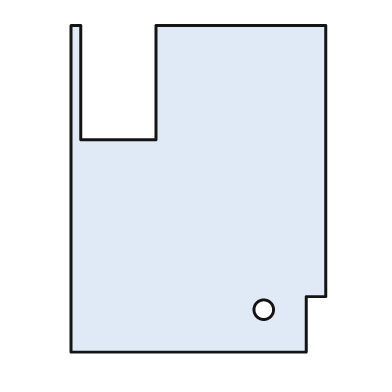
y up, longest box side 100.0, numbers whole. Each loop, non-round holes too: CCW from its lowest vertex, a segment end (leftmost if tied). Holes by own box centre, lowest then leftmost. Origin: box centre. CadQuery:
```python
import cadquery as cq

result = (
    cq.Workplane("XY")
    .moveTo(-39.0, -50.0)
    .lineTo(33.0, -50.0)
    .lineTo(33.0, -33.0)
    .lineTo(39.0, -33.0)
    .lineTo(39.0, 50.0)
    .lineTo(-13.0, 50.0)
    .lineTo(-13.0, 15.0)
    .lineTo(-36.0, 15.0)
    .lineTo(-36.0, 50.0)
    .lineTo(-39.0, 50.0)
    .close()
    .moveTo(20.0, -37.0)
    .circle(3.0)
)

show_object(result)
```